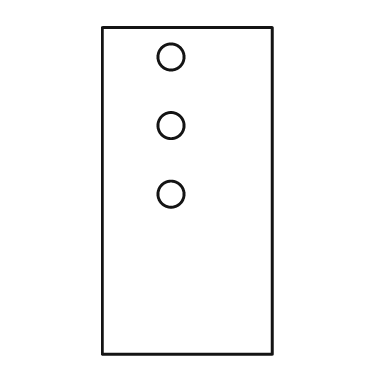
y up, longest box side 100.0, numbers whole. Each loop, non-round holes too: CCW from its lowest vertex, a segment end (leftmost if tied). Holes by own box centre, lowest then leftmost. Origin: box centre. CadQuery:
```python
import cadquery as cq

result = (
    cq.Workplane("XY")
    .moveTo(-26.0, -50.0)
    .lineTo(26.0, -50.0)
    .lineTo(26.0, 50.0)
    .lineTo(-26.0, 50.0)
    .close()
    .moveTo(-5.0, -1.0)
    .circle(4.0)
    .moveTo(-5.0, 20.0)
    .circle(4.0)
    .moveTo(-5.0, 41.0)
    .circle(4.0)
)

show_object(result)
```